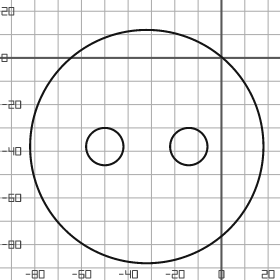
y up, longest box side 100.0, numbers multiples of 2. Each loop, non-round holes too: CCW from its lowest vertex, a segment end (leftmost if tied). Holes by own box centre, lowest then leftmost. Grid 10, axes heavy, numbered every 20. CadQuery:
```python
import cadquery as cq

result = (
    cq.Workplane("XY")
    .moveTo(-32.0, -38.0)
    .circle(50.0)
    .moveTo(-50.0, -38.0)
    .circle(8.0)
    .moveTo(-14.0, -38.0)
    .circle(8.0)
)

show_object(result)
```